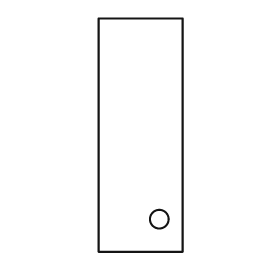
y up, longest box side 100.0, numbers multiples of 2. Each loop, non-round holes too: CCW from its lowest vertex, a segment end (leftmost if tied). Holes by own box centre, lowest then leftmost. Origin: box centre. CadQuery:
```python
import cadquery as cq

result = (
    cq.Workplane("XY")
    .moveTo(-18.0, -50.0)
    .lineTo(18.0, -50.0)
    .lineTo(18.0, 50.0)
    .lineTo(-18.0, 50.0)
    .close()
    .moveTo(8.0, -36.0)
    .circle(4.0)
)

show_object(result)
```